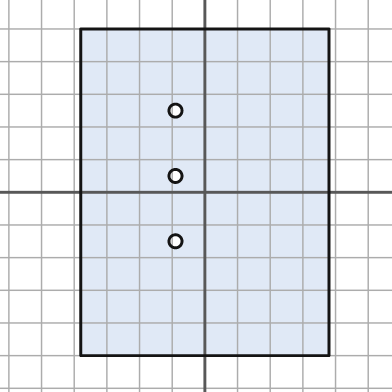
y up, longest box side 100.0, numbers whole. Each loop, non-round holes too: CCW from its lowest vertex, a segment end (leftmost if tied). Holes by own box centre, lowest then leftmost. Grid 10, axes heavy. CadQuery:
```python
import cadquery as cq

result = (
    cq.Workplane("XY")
    .moveTo(-38.0, -50.0)
    .lineTo(38.0, -50.0)
    .lineTo(38.0, 50.0)
    .lineTo(-38.0, 50.0)
    .close()
    .moveTo(-9.0, -15.0)
    .circle(2.0)
    .moveTo(-9.0, 5.0)
    .circle(2.0)
    .moveTo(-9.0, 25.0)
    .circle(2.0)
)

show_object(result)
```